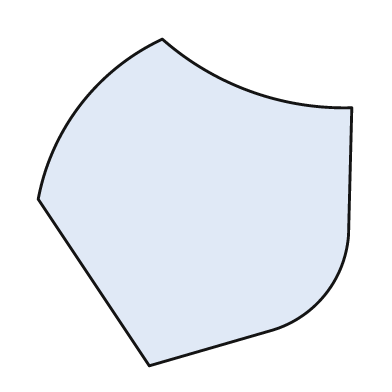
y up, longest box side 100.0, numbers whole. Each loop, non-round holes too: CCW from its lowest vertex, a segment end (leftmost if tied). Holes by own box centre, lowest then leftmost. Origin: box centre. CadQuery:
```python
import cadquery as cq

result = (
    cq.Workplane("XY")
    .moveTo(-14.0, -50.0)
    .lineTo(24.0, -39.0)
    .threePointArc((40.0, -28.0), (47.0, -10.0))
    .lineTo(48.0, 29.0)
    .threePointArc((17.0, 34.0), (-10.0, 50.0))
    .threePointArc((-35.0, 30.0), (-48.0, 1.0))
    .close()
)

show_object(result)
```